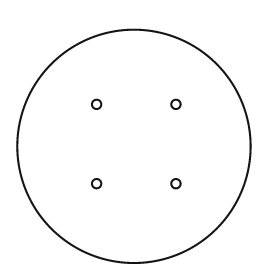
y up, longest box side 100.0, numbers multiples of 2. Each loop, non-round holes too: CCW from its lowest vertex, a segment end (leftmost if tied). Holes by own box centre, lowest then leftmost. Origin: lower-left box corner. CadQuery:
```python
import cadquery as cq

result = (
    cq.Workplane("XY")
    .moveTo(50.0, 50.0)
    .circle(50.0)
    .moveTo(34.0, 34.0)
    .circle(2.0)
    .moveTo(68.0, 34.0)
    .circle(2.0)
    .moveTo(34.0, 68.0)
    .circle(2.0)
    .moveTo(68.0, 68.0)
    .circle(2.0)
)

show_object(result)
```